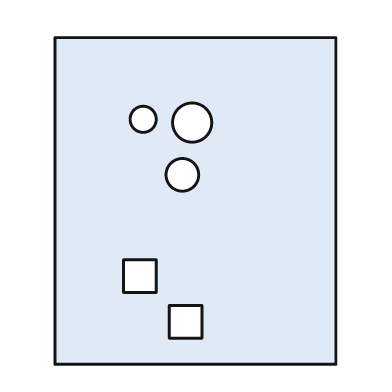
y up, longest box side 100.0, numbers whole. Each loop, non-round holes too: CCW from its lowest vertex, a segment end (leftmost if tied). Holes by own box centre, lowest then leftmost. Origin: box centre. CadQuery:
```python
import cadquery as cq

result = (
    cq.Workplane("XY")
    .moveTo(-43.0, -50.0)
    .lineTo(43.0, -50.0)
    .lineTo(43.0, 50.0)
    .lineTo(-43.0, 50.0)
    .close()
    .moveTo(-8.0, -42.0)
    .lineTo(2.0, -42.0)
    .lineTo(2.0, -32.0)
    .lineTo(-8.0, -32.0)
    .close()
    .moveTo(-22.0, -28.0)
    .lineTo(-12.0, -28.0)
    .lineTo(-12.0, -18.0)
    .lineTo(-22.0, -18.0)
    .close()
    .moveTo(-4.0, 8.0)
    .circle(5.0)
    .moveTo(-1.0, 24.0)
    .circle(6.0)
    .moveTo(-16.0, 25.0)
    .circle(4.0)
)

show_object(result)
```